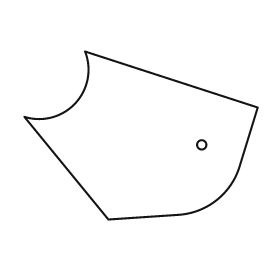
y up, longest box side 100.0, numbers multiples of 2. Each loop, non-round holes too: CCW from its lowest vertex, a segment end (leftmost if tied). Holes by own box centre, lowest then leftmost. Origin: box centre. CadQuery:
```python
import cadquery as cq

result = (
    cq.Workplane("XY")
    .moveTo(-14.0, -36.0)
    .lineTo(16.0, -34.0)
    .threePointArc((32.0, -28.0), (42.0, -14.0))
    .lineTo(50.0, 12.0)
    .lineTo(-24.0, 36.0)
    .threePointArc((-28.0, 14.0), (-50.0, 8.0))
    .close()
    .moveTo(26.0, -4.0)
    .circle(2.0)
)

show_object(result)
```